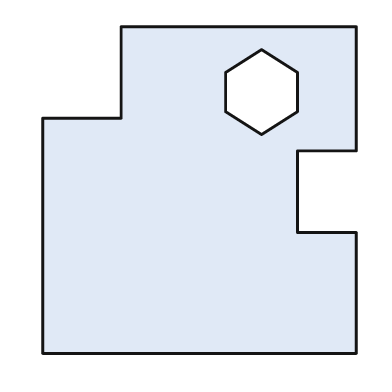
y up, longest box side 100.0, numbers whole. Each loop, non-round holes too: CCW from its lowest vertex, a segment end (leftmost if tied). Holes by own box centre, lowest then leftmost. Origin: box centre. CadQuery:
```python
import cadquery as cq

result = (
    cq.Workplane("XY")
    .moveTo(-48.0, -50.0)
    .lineTo(48.0, -50.0)
    .lineTo(48.0, -13.0)
    .lineTo(30.0, -13.0)
    .lineTo(30.0, 12.0)
    .lineTo(48.0, 12.0)
    .lineTo(48.0, 50.0)
    .lineTo(-24.0, 50.0)
    .lineTo(-24.0, 22.0)
    .lineTo(-48.0, 22.0)
    .close()
    .moveTo(19.0, 17.0)
    .lineTo(30.0, 24.0)
    .lineTo(30.0, 36.0)
    .lineTo(19.0, 43.0)
    .lineTo(8.0, 36.0)
    .lineTo(8.0, 24.0)
    .close()
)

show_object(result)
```